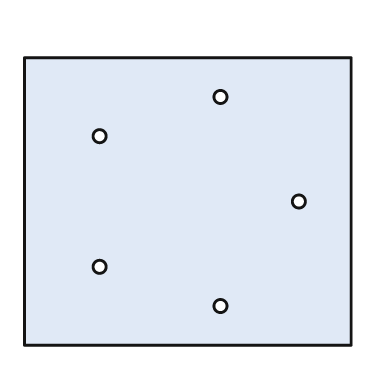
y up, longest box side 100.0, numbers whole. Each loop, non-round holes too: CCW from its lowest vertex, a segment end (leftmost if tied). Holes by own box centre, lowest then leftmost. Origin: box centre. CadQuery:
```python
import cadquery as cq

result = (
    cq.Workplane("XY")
    .moveTo(-50.0, -44.0)
    .lineTo(50.0, -44.0)
    .lineTo(50.0, 44.0)
    .lineTo(-50.0, 44.0)
    .close()
    .moveTo(10.0, -32.0)
    .circle(2.0)
    .moveTo(-27.0, -20.0)
    .circle(2.0)
    .moveTo(34.0, 0.0)
    .circle(2.0)
    .moveTo(-27.0, 20.0)
    .circle(2.0)
    .moveTo(10.0, 32.0)
    .circle(2.0)
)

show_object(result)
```